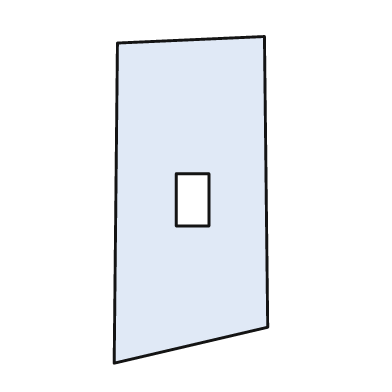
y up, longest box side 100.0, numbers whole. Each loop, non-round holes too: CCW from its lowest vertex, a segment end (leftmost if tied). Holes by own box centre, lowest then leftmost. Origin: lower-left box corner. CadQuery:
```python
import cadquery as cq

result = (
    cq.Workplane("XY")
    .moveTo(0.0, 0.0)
    .lineTo(47.0, 11.0)
    .lineTo(46.0, 100.0)
    .lineTo(1.0, 98.0)
    .close()
    .moveTo(19.0, 42.0)
    .lineTo(29.0, 42.0)
    .lineTo(29.0, 58.0)
    .lineTo(19.0, 58.0)
    .close()
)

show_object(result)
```